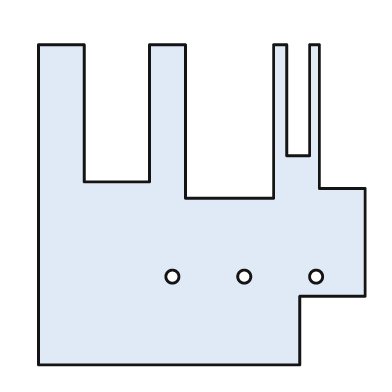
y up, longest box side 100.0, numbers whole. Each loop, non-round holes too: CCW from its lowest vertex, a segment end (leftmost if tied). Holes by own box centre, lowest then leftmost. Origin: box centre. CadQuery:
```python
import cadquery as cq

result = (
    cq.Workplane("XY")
    .moveTo(-50.0, -49.0)
    .lineTo(30.0, -49.0)
    .lineTo(30.0, -28.0)
    .lineTo(50.0, -28.0)
    .lineTo(50.0, 5.0)
    .lineTo(36.0, 5.0)
    .lineTo(36.0, 49.0)
    .lineTo(33.0, 49.0)
    .lineTo(33.0, 15.0)
    .lineTo(26.0, 15.0)
    .lineTo(26.0, 49.0)
    .lineTo(22.0, 49.0)
    .lineTo(22.0, 2.0)
    .lineTo(-5.0, 2.0)
    .lineTo(-5.0, 49.0)
    .lineTo(-16.0, 49.0)
    .lineTo(-16.0, 7.0)
    .lineTo(-36.0, 7.0)
    .lineTo(-36.0, 49.0)
    .lineTo(-50.0, 49.0)
    .close()
    .moveTo(-9.0, -22.0)
    .circle(2.0)
    .moveTo(13.0, -22.0)
    .circle(2.0)
    .moveTo(35.0, -22.0)
    .circle(2.0)
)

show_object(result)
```